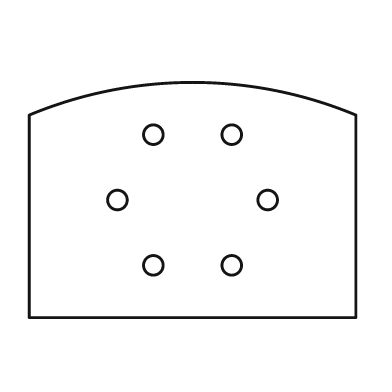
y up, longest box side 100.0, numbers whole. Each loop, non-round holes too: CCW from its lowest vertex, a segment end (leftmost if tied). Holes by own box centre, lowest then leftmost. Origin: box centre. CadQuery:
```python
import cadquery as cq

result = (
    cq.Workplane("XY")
    .moveTo(-50.0, -36.0)
    .lineTo(50.0, -36.0)
    .lineTo(50.0, 26.0)
    .threePointArc((0.0, 36.0), (-50.0, 26.0))
    .close()
    .moveTo(-12.0, -20.0)
    .circle(3.0)
    .moveTo(12.0, -20.0)
    .circle(3.0)
    .moveTo(-23.0, 0.0)
    .circle(3.0)
    .moveTo(23.0, 0.0)
    .circle(3.0)
    .moveTo(-12.0, 20.0)
    .circle(3.0)
    .moveTo(12.0, 20.0)
    .circle(3.0)
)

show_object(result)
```